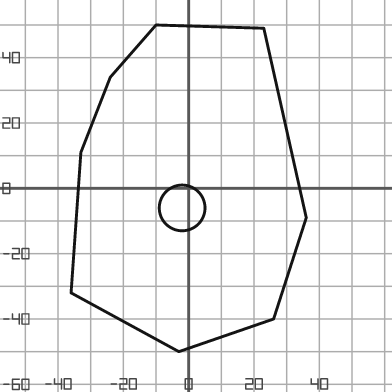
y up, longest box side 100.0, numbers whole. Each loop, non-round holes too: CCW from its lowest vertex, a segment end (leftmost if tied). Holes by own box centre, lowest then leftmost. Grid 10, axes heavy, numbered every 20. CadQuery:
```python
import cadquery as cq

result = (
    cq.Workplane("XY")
    .moveTo(-3.0, -50.0)
    .lineTo(26.0, -40.0)
    .lineTo(36.0, -9.0)
    .lineTo(23.0, 49.0)
    .lineTo(-10.0, 50.0)
    .lineTo(-24.0, 34.0)
    .lineTo(-33.0, 11.0)
    .lineTo(-36.0, -32.0)
    .close()
    .moveTo(-2.0, -6.0)
    .circle(7.0)
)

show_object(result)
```